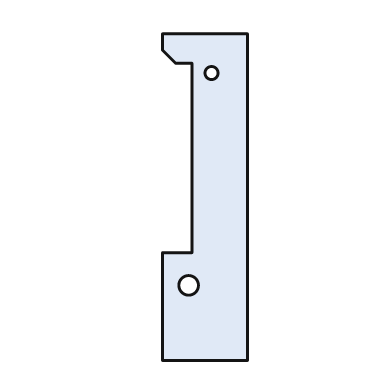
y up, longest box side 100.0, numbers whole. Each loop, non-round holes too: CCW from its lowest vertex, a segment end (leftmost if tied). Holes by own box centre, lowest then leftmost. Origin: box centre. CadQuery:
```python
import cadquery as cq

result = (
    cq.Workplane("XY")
    .moveTo(-13.0, -50.0)
    .lineTo(13.0, -50.0)
    .lineTo(13.0, 50.0)
    .lineTo(-13.0, 50.0)
    .lineTo(-13.0, 45.0)
    .lineTo(-9.0, 41.0)
    .lineTo(-4.0, 41.0)
    .lineTo(-4.0, -17.0)
    .lineTo(-13.0, -17.0)
    .close()
    .moveTo(-5.0, -27.0)
    .circle(3.0)
    .moveTo(2.0, 38.0)
    .circle(2.0)
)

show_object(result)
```